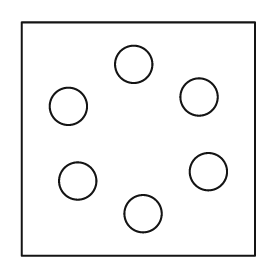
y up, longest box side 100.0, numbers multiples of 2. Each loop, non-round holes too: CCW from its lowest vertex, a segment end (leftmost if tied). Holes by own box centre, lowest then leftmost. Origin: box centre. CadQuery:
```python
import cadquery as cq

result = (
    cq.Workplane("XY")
    .moveTo(-50.0, -50.0)
    .lineTo(50.0, -50.0)
    .lineTo(50.0, 50.0)
    .lineTo(-50.0, 50.0)
    .close()
    .moveTo(2.0, -32.0)
    .circle(8.0)
    .moveTo(-26.0, -18.0)
    .circle(8.0)
    .moveTo(30.0, -14.0)
    .circle(8.0)
    .moveTo(-30.0, 14.0)
    .circle(8.0)
    .moveTo(26.0, 18.0)
    .circle(8.0)
    .moveTo(-2.0, 32.0)
    .circle(8.0)
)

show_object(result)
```